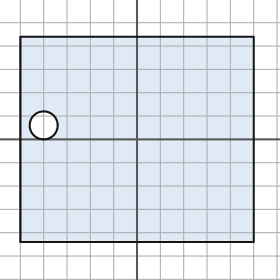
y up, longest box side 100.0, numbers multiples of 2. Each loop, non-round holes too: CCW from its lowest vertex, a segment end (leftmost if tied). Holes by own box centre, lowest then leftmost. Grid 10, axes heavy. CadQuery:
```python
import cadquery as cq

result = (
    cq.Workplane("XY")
    .moveTo(-50.0, -44.0)
    .lineTo(50.0, -44.0)
    .lineTo(50.0, 44.0)
    .lineTo(-50.0, 44.0)
    .close()
    .moveTo(-40.0, 6.0)
    .circle(6.0)
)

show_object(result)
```